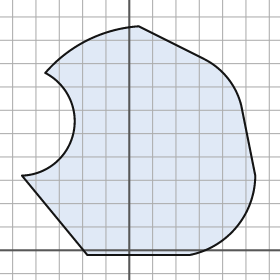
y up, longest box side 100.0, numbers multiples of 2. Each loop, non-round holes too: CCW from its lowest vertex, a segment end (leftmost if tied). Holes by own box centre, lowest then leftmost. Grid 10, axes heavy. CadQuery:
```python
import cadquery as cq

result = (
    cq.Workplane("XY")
    .moveTo(-18.0, -2.0)
    .lineTo(26.0, -2.0)
    .threePointArc((46.0, 10.0), (54.0, 32.0))
    .lineTo(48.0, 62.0)
    .threePointArc((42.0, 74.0), (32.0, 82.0))
    .lineTo(4.0, 96.0)
    .threePointArc((-18.0, 90.0), (-36.0, 76.0))
    .threePointArc((-24.0, 50.0), (-46.0, 32.0))
    .close()
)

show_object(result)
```